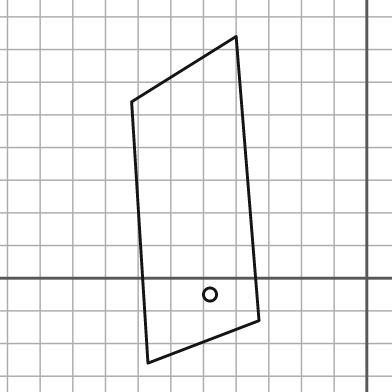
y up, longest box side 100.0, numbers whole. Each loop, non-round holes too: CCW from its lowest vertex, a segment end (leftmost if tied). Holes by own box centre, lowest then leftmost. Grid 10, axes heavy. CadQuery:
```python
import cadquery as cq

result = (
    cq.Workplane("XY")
    .moveTo(-67.0, -26.0)
    .lineTo(-33.0, -13.0)
    .lineTo(-40.0, 74.0)
    .lineTo(-72.0, 54.0)
    .close()
    .moveTo(-48.0, -5.0)
    .circle(2.0)
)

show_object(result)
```